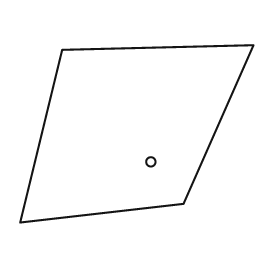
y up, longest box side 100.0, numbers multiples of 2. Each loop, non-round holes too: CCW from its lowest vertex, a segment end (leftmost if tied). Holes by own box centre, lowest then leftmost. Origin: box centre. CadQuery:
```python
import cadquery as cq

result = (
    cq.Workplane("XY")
    .moveTo(-50.0, -38.0)
    .lineTo(20.0, -30.0)
    .lineTo(50.0, 38.0)
    .lineTo(-32.0, 36.0)
    .close()
    .moveTo(6.0, -12.0)
    .circle(2.0)
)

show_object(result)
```